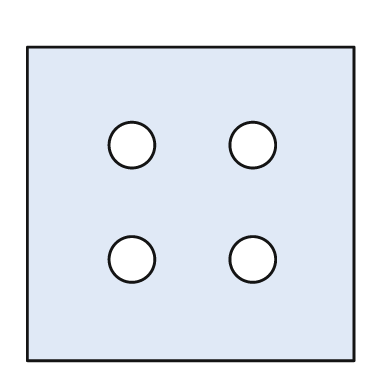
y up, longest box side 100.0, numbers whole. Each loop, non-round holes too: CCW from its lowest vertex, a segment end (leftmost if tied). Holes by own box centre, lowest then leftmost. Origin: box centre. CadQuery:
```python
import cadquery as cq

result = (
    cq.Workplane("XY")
    .moveTo(-50.0, -48.0)
    .lineTo(50.0, -48.0)
    .lineTo(50.0, 48.0)
    .lineTo(-50.0, 48.0)
    .close()
    .moveTo(-18.0, -17.0)
    .circle(7.0)
    .moveTo(19.0, -17.0)
    .circle(7.0)
    .moveTo(-18.0, 18.0)
    .circle(7.0)
    .moveTo(19.0, 18.0)
    .circle(7.0)
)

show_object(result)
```